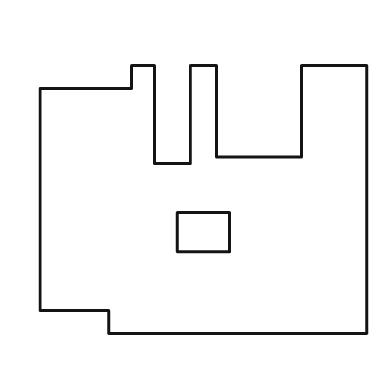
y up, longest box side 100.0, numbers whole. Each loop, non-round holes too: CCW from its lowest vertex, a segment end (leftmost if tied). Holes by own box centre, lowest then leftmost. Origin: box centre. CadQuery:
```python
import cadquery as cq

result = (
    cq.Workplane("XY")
    .moveTo(-29.0, -41.0)
    .lineTo(50.0, -41.0)
    .lineTo(50.0, 41.0)
    .lineTo(30.0, 41.0)
    .lineTo(30.0, 13.0)
    .lineTo(4.0, 13.0)
    .lineTo(4.0, 41.0)
    .lineTo(-4.0, 41.0)
    .lineTo(-4.0, 11.0)
    .lineTo(-15.0, 11.0)
    .lineTo(-15.0, 41.0)
    .lineTo(-22.0, 41.0)
    .lineTo(-22.0, 34.0)
    .lineTo(-50.0, 34.0)
    .lineTo(-50.0, -34.0)
    .lineTo(-29.0, -34.0)
    .close()
    .moveTo(-8.0, -16.0)
    .lineTo(8.0, -16.0)
    .lineTo(8.0, -4.0)
    .lineTo(-8.0, -4.0)
    .close()
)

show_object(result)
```